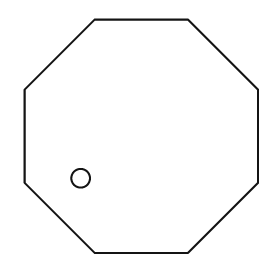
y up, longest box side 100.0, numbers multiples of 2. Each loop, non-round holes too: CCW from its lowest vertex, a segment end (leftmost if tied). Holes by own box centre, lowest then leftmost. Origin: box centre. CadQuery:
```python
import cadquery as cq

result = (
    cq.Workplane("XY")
    .moveTo(-20.0, -50.0)
    .lineTo(20.0, -50.0)
    .lineTo(50.0, -20.0)
    .lineTo(50.0, 20.0)
    .lineTo(20.0, 50.0)
    .lineTo(-20.0, 50.0)
    .lineTo(-50.0, 20.0)
    .lineTo(-50.0, -20.0)
    .close()
    .moveTo(-26.0, -18.0)
    .circle(4.0)
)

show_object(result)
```